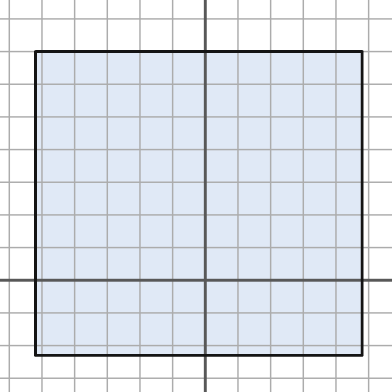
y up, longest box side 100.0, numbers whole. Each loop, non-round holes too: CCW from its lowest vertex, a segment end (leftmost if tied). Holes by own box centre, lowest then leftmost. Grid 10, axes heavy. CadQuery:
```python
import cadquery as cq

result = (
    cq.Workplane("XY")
    .moveTo(-52.0, -23.0)
    .lineTo(48.0, -23.0)
    .lineTo(48.0, 70.0)
    .lineTo(-52.0, 70.0)
    .close()
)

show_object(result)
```